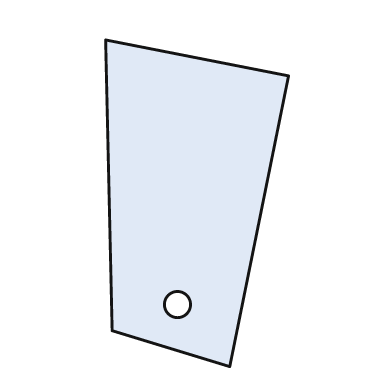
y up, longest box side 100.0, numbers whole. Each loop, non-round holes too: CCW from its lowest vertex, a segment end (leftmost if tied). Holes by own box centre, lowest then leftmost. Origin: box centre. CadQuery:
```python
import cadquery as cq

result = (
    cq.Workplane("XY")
    .moveTo(10.0, -50.0)
    .lineTo(28.0, 39.0)
    .lineTo(-28.0, 50.0)
    .lineTo(-26.0, -39.0)
    .close()
    .moveTo(-6.0, -31.0)
    .circle(4.0)
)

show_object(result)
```